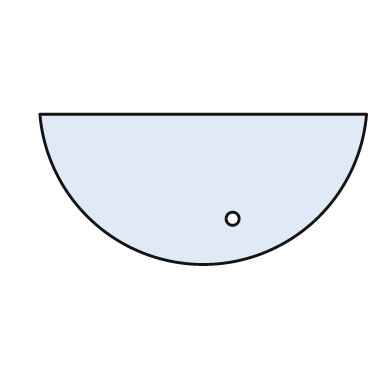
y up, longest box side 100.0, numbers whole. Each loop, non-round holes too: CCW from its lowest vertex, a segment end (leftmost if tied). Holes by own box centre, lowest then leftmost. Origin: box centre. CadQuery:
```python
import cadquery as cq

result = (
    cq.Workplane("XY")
    .moveTo(-50.0, 23.0)
    .threePointArc((0.0, -23.0), (50.0, 23.0))
    .close()
    .moveTo(9.0, -9.0)
    .circle(2.0)
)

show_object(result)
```